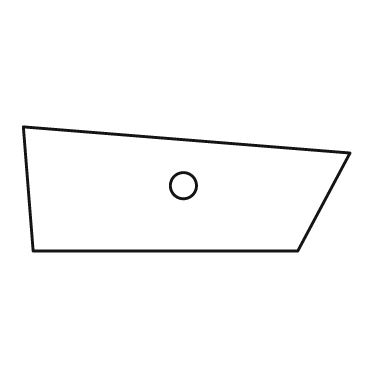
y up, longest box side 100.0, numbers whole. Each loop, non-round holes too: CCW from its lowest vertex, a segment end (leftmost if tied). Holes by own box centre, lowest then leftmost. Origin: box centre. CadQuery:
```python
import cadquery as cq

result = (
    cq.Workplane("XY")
    .moveTo(-47.0, -19.0)
    .lineTo(34.0, -19.0)
    .lineTo(50.0, 11.0)
    .lineTo(-50.0, 19.0)
    .close()
    .moveTo(-1.0, 1.0)
    .circle(4.0)
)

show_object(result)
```